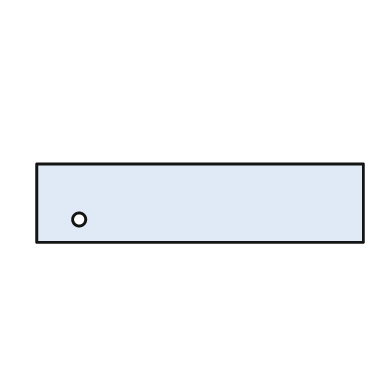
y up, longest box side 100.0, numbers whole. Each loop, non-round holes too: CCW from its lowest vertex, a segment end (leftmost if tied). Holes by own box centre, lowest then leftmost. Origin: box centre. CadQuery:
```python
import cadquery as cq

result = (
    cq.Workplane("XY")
    .moveTo(-50.0, -12.0)
    .lineTo(50.0, -12.0)
    .lineTo(50.0, 12.0)
    .lineTo(-50.0, 12.0)
    .close()
    .moveTo(-37.0, -5.0)
    .circle(2.0)
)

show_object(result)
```